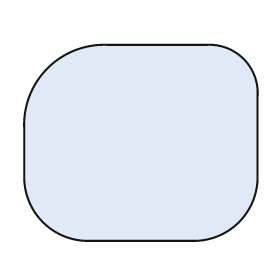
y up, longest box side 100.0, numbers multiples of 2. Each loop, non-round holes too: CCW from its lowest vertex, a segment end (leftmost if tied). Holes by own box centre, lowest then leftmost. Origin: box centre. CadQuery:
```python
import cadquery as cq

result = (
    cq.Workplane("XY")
    .moveTo(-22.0, -42.0)
    .lineTo(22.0, -42.0)
    .threePointArc((42.0, -34.0), (50.0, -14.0))
    .lineTo(50.0, 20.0)
    .threePointArc((44.0, 36.0), (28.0, 42.0))
    .lineTo(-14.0, 42.0)
    .threePointArc((-40.0, 32.0), (-50.0, 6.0))
    .lineTo(-50.0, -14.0)
    .threePointArc((-42.0, -34.0), (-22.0, -42.0))
    .close()
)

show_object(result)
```